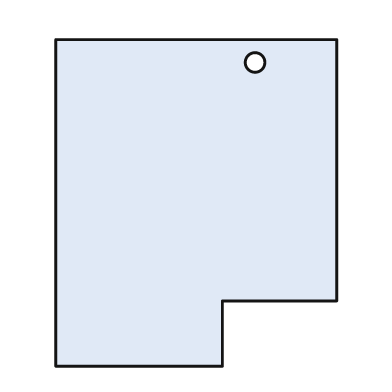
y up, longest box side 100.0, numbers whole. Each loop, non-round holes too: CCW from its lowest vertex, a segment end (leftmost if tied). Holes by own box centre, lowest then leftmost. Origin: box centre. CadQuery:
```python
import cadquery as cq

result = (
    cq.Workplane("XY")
    .moveTo(-43.0, -50.0)
    .lineTo(8.0, -50.0)
    .lineTo(8.0, -30.0)
    .lineTo(43.0, -30.0)
    .lineTo(43.0, 50.0)
    .lineTo(-43.0, 50.0)
    .close()
    .moveTo(18.0, 43.0)
    .circle(3.0)
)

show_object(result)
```